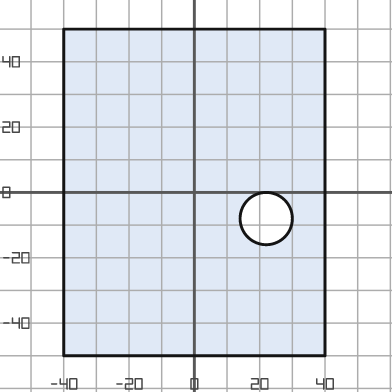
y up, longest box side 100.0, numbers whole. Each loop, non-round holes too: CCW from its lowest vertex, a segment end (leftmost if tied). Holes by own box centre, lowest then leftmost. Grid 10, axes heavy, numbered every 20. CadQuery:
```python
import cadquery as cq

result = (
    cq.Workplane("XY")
    .moveTo(-40.0, -50.0)
    .lineTo(40.0, -50.0)
    .lineTo(40.0, 50.0)
    .lineTo(-40.0, 50.0)
    .close()
    .moveTo(22.0, -8.0)
    .circle(8.0)
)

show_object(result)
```